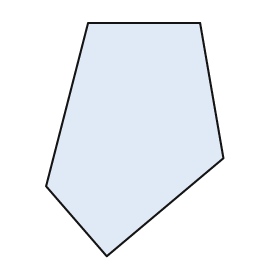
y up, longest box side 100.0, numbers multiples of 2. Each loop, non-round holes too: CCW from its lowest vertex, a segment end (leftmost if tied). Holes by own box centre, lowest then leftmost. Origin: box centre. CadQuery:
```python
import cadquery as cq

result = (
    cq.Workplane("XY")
    .moveTo(-12.0, -50.0)
    .lineTo(38.0, -8.0)
    .lineTo(28.0, 50.0)
    .lineTo(-20.0, 50.0)
    .lineTo(-38.0, -20.0)
    .close()
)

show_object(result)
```